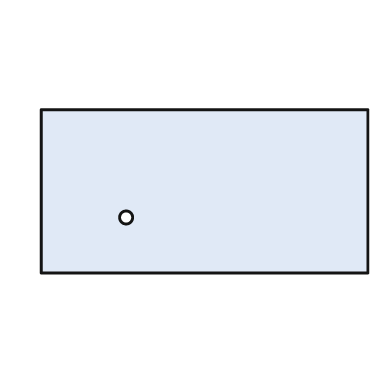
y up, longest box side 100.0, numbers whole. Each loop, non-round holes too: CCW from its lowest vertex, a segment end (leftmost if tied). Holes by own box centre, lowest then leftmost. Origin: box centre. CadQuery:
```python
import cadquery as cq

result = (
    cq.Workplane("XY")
    .moveTo(-50.0, -25.0)
    .lineTo(50.0, -25.0)
    .lineTo(50.0, 25.0)
    .lineTo(-50.0, 25.0)
    .close()
    .moveTo(-24.0, -8.0)
    .circle(2.0)
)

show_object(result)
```